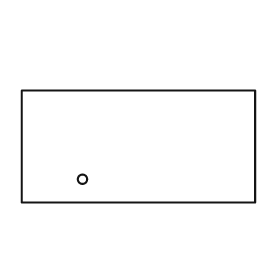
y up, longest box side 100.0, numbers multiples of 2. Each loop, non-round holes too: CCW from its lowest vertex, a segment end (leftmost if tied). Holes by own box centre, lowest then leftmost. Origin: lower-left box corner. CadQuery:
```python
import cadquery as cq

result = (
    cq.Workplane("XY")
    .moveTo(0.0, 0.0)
    .lineTo(100.0, 0.0)
    .lineTo(100.0, 48.0)
    .lineTo(0.0, 48.0)
    .close()
    .moveTo(26.0, 10.0)
    .circle(2.0)
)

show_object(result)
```